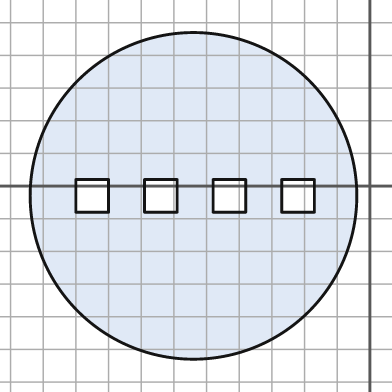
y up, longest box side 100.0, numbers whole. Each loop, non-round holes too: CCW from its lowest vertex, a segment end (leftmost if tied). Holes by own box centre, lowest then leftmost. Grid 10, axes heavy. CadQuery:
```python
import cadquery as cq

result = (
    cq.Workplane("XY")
    .moveTo(-54.0, -3.0)
    .circle(50.0)
    .moveTo(-90.0, -8.0)
    .lineTo(-80.0, -8.0)
    .lineTo(-80.0, 2.0)
    .lineTo(-90.0, 2.0)
    .close()
    .moveTo(-69.0, -8.0)
    .lineTo(-59.0, -8.0)
    .lineTo(-59.0, 2.0)
    .lineTo(-69.0, 2.0)
    .close()
    .moveTo(-48.0, -8.0)
    .lineTo(-38.0, -8.0)
    .lineTo(-38.0, 2.0)
    .lineTo(-48.0, 2.0)
    .close()
    .moveTo(-27.0, -8.0)
    .lineTo(-17.0, -8.0)
    .lineTo(-17.0, 2.0)
    .lineTo(-27.0, 2.0)
    .close()
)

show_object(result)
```